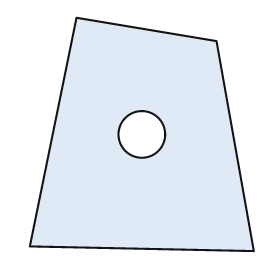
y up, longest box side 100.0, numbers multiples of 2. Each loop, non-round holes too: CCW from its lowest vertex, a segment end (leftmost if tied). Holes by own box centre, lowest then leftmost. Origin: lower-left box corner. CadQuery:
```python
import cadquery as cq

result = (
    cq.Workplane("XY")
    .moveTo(96.0, 0.0)
    .lineTo(80.0, 90.0)
    .lineTo(20.0, 100.0)
    .lineTo(0.0, 2.0)
    .close()
    .moveTo(48.0, 50.0)
    .circle(10.0)
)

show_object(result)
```